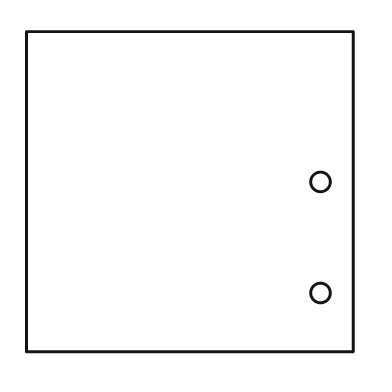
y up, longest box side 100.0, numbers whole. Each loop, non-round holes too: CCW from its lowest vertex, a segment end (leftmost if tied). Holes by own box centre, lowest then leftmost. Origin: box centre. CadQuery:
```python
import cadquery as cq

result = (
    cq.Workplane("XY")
    .moveTo(-50.0, -49.0)
    .lineTo(50.0, -49.0)
    .lineTo(50.0, 49.0)
    .lineTo(-50.0, 49.0)
    .close()
    .moveTo(40.0, -31.0)
    .circle(3.0)
    .moveTo(40.0, 3.0)
    .circle(3.0)
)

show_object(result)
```